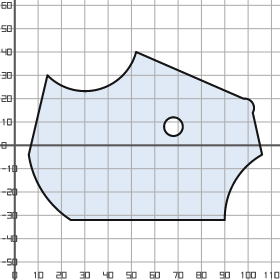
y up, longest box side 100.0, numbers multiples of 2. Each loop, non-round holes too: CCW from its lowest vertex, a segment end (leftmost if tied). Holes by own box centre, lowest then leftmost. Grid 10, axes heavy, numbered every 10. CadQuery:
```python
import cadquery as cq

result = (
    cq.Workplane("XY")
    .moveTo(24.0, -32.0)
    .lineTo(90.0, -32.0)
    .threePointArc((94.0, -16.0), (106.0, -4.0))
    .lineTo(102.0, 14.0)
    .threePointArc((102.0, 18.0), (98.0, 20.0))
    .lineTo(52.0, 40.0)
    .threePointArc((36.0, 24.0), (14.0, 30.0))
    .lineTo(6.0, -4.0)
    .threePointArc((12.0, -20.0), (24.0, -32.0))
    .close()
    .moveTo(68.0, 8.0)
    .circle(4.0)
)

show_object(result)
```